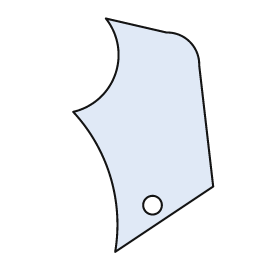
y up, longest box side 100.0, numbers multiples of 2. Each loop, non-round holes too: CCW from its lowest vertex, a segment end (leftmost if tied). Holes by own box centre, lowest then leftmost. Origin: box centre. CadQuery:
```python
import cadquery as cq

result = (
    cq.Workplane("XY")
    .moveTo(-12.0, -50.0)
    .lineTo(30.0, -22.0)
    .lineTo(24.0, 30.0)
    .threePointArc((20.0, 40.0), (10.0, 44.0))
    .lineTo(-16.0, 50.0)
    .threePointArc((-12.0, 26.0), (-30.0, 10.0))
    .threePointArc((-14.0, -18.0), (-12.0, -50.0))
    .close()
    .moveTo(4.0, -30.0)
    .circle(4.0)
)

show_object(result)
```